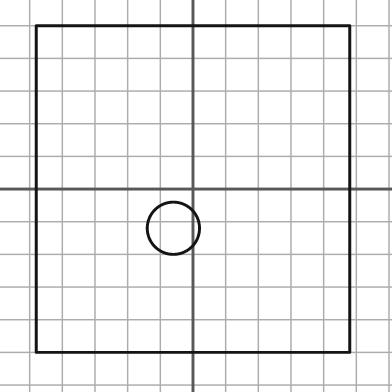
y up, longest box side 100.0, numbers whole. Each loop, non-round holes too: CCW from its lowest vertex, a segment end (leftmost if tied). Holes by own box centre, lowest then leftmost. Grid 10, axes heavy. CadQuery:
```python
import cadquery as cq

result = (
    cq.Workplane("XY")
    .moveTo(-48.0, -50.0)
    .lineTo(48.0, -50.0)
    .lineTo(48.0, 50.0)
    .lineTo(-48.0, 50.0)
    .close()
    .moveTo(-6.0, -12.0)
    .circle(8.0)
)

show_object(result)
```